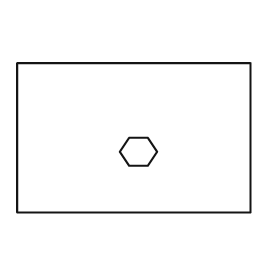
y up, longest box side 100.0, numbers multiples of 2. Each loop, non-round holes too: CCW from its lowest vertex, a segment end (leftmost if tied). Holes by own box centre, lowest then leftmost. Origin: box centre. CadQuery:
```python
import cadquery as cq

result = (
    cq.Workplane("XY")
    .moveTo(-50.0, -32.0)
    .lineTo(50.0, -32.0)
    .lineTo(50.0, 32.0)
    .lineTo(-50.0, 32.0)
    .close()
    .moveTo(-2.0, -12.0)
    .lineTo(6.0, -12.0)
    .lineTo(10.0, -6.0)
    .lineTo(6.0, 0.0)
    .lineTo(-2.0, 0.0)
    .lineTo(-6.0, -6.0)
    .close()
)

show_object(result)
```